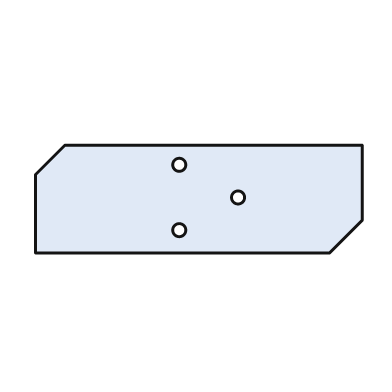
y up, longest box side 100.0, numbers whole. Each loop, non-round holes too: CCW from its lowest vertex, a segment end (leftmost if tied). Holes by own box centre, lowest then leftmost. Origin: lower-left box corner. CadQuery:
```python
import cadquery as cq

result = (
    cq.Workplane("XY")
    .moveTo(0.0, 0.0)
    .lineTo(90.0, 0.0)
    .lineTo(100.0, 10.0)
    .lineTo(100.0, 33.0)
    .lineTo(9.0, 33.0)
    .lineTo(0.0, 24.0)
    .close()
    .moveTo(44.0, 7.0)
    .circle(2.0)
    .moveTo(62.0, 17.0)
    .circle(2.0)
    .moveTo(44.0, 27.0)
    .circle(2.0)
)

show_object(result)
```